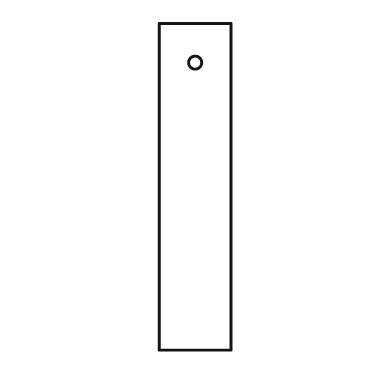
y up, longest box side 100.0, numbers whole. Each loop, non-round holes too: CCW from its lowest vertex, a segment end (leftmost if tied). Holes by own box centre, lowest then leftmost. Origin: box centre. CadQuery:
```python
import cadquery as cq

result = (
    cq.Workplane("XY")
    .moveTo(-11.0, -50.0)
    .lineTo(11.0, -50.0)
    .lineTo(11.0, 50.0)
    .lineTo(-11.0, 50.0)
    .close()
    .moveTo(0.0, 38.0)
    .circle(2.0)
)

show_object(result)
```